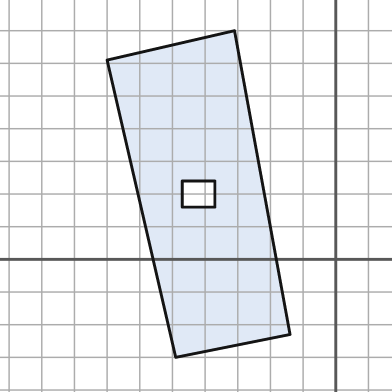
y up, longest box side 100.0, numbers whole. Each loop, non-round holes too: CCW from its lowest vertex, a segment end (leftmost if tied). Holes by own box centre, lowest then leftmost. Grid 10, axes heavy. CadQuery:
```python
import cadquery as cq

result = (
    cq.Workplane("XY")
    .moveTo(-49.0, -30.0)
    .lineTo(-14.0, -23.0)
    .lineTo(-31.0, 70.0)
    .lineTo(-70.0, 61.0)
    .close()
    .moveTo(-47.0, 16.0)
    .lineTo(-37.0, 16.0)
    .lineTo(-37.0, 24.0)
    .lineTo(-47.0, 24.0)
    .close()
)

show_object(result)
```